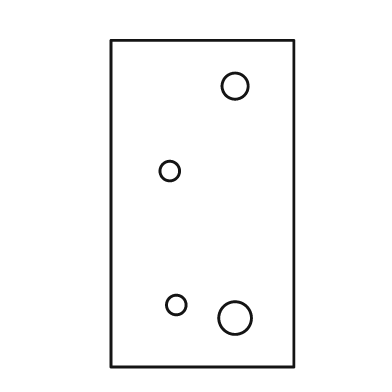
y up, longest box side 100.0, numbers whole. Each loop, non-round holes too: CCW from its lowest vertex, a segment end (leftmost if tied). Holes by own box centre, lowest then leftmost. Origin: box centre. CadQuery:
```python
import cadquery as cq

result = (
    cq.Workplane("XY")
    .moveTo(-28.0, -50.0)
    .lineTo(28.0, -50.0)
    .lineTo(28.0, 50.0)
    .lineTo(-28.0, 50.0)
    .close()
    .moveTo(10.0, -35.0)
    .circle(5.0)
    .moveTo(-8.0, -31.0)
    .circle(3.0)
    .moveTo(-10.0, 10.0)
    .circle(3.0)
    .moveTo(10.0, 36.0)
    .circle(4.0)
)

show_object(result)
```